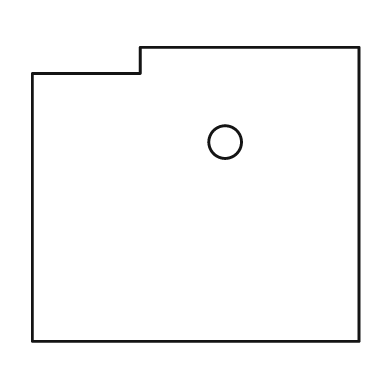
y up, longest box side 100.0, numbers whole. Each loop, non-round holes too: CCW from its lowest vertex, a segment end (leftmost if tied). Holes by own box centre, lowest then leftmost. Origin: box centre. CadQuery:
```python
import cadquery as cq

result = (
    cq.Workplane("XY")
    .moveTo(-50.0, -45.0)
    .lineTo(50.0, -45.0)
    .lineTo(50.0, 45.0)
    .lineTo(-17.0, 45.0)
    .lineTo(-17.0, 37.0)
    .lineTo(-50.0, 37.0)
    .close()
    .moveTo(9.0, 16.0)
    .circle(5.0)
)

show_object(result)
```